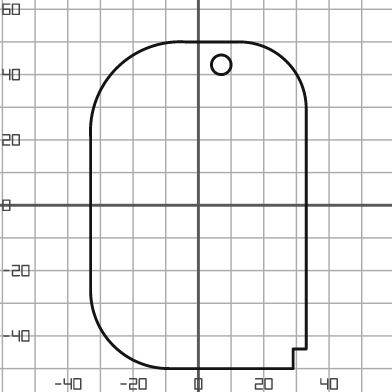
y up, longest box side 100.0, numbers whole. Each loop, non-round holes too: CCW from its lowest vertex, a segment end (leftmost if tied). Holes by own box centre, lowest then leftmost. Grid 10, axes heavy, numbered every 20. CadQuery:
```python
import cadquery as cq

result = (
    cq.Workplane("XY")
    .moveTo(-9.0, -50.0)
    .lineTo(29.0, -50.0)
    .lineTo(29.0, -44.0)
    .lineTo(33.0, -44.0)
    .lineTo(33.0, 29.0)
    .threePointArc((27.0, 44.0), (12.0, 50.0))
    .lineTo(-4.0, 50.0)
    .threePointArc((-25.0, 42.0), (-33.0, 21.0))
    .lineTo(-33.0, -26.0)
    .threePointArc((-26.0, -43.0), (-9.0, -50.0))
    .close()
    .moveTo(7.0, 43.0)
    .circle(3.0)
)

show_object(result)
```